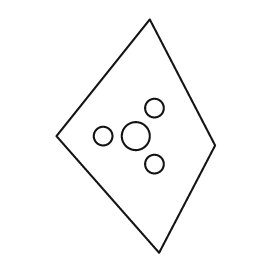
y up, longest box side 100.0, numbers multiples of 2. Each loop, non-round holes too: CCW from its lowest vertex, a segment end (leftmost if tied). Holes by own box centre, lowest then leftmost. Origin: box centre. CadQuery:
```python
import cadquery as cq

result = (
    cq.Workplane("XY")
    .moveTo(10.0, -50.0)
    .lineTo(34.0, -4.0)
    .lineTo(6.0, 50.0)
    .lineTo(-34.0, 0.0)
    .close()
    .moveTo(8.0, -12.0)
    .circle(4.0)
    .moveTo(-14.0, 0.0)
    .circle(4.0)
    .moveTo(0.0, 0.0)
    .circle(6.0)
    .moveTo(8.0, 12.0)
    .circle(4.0)
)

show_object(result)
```